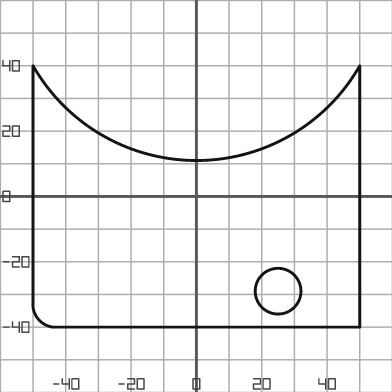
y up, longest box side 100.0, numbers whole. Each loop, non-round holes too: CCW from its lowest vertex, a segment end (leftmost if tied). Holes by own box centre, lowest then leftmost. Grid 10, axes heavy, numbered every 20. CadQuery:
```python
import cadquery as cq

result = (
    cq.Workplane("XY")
    .moveTo(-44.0, -40.0)
    .lineTo(50.0, -40.0)
    .lineTo(50.0, 40.0)
    .threePointArc((0.0, 11.0), (-50.0, 40.0))
    .lineTo(-50.0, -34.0)
    .threePointArc((-48.0, -38.0), (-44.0, -40.0))
    .close()
    .moveTo(25.0, -29.0)
    .circle(7.0)
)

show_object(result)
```